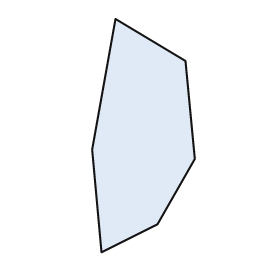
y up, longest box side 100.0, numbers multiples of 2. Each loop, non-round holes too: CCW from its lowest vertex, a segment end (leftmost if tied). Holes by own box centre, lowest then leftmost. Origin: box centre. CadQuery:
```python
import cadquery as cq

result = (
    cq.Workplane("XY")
    .moveTo(-18.0, -50.0)
    .lineTo(6.0, -38.0)
    .lineTo(22.0, -10.0)
    .lineTo(18.0, 32.0)
    .lineTo(-12.0, 50.0)
    .lineTo(-22.0, -6.0)
    .close()
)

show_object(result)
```